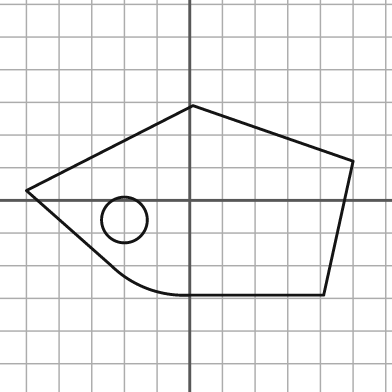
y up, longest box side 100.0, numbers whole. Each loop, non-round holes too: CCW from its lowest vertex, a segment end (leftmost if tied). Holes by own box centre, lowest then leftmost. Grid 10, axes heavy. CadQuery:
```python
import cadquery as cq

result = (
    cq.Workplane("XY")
    .moveTo(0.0, -29.0)
    .lineTo(41.0, -29.0)
    .lineTo(50.0, 12.0)
    .lineTo(1.0, 29.0)
    .lineTo(-50.0, 3.0)
    .lineTo(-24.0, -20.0)
    .threePointArc((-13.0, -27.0), (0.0, -29.0))
    .close()
    .moveTo(-20.0, -6.0)
    .circle(7.0)
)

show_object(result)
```